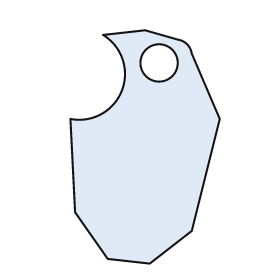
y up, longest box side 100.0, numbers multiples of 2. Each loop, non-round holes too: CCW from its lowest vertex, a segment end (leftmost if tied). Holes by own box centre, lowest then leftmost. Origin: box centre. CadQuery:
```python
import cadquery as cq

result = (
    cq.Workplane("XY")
    .moveTo(2.0, -50.0)
    .lineTo(20.0, -36.0)
    .lineTo(32.0, 12.0)
    .lineTo(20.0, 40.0)
    .threePointArc((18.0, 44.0), (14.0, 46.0))
    .lineTo(0.0, 50.0)
    .lineTo(-18.0, 48.0)
    .threePointArc((-10.0, 24.0), (-32.0, 12.0))
    .lineTo(-30.0, -28.0)
    .lineTo(-16.0, -48.0)
    .close()
    .moveTo(6.0, 36.0)
    .circle(8.0)
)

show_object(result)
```